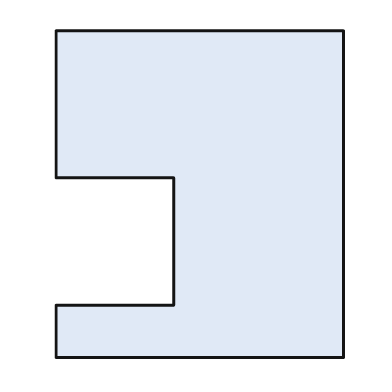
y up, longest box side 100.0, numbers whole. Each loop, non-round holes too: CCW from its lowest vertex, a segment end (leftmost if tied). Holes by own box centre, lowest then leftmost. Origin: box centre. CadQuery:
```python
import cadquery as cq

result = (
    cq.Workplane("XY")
    .moveTo(-44.0, -50.0)
    .lineTo(44.0, -50.0)
    .lineTo(44.0, 50.0)
    .lineTo(-44.0, 50.0)
    .lineTo(-44.0, 5.0)
    .lineTo(-8.0, 5.0)
    .lineTo(-8.0, -34.0)
    .lineTo(-44.0, -34.0)
    .close()
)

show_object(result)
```